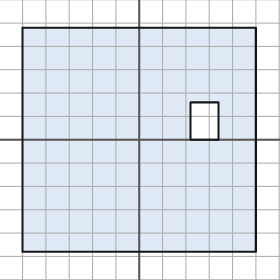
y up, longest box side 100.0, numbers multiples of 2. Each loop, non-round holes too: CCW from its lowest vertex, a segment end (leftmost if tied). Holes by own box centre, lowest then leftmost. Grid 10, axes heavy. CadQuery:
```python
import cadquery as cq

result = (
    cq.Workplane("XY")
    .moveTo(-50.0, -48.0)
    .lineTo(50.0, -48.0)
    .lineTo(50.0, 48.0)
    .lineTo(-50.0, 48.0)
    .close()
    .moveTo(22.0, 0.0)
    .lineTo(34.0, 0.0)
    .lineTo(34.0, 16.0)
    .lineTo(22.0, 16.0)
    .close()
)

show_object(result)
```